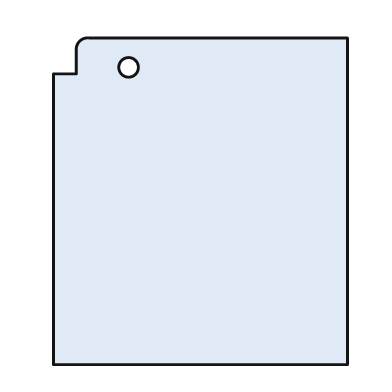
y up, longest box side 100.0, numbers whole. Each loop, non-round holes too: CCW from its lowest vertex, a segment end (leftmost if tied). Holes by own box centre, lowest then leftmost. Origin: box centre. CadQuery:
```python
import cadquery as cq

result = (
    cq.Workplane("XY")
    .moveTo(-45.0, -50.0)
    .lineTo(45.0, -50.0)
    .lineTo(45.0, 50.0)
    .lineTo(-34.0, 50.0)
    .threePointArc((-37.0, 49.0), (-38.0, 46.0))
    .lineTo(-38.0, 39.0)
    .lineTo(-45.0, 39.0)
    .close()
    .moveTo(-22.0, 41.0)
    .circle(3.0)
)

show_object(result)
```